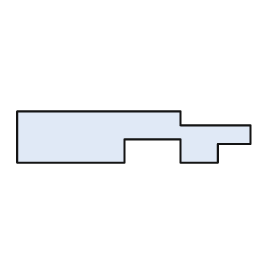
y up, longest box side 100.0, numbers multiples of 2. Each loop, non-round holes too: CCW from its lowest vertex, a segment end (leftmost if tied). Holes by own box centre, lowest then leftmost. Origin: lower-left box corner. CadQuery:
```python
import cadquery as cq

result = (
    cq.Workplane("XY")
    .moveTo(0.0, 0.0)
    .lineTo(46.0, 0.0)
    .lineTo(46.0, 10.0)
    .lineTo(70.0, 10.0)
    .lineTo(70.0, 0.0)
    .lineTo(86.0, 0.0)
    .lineTo(86.0, 8.0)
    .lineTo(100.0, 8.0)
    .lineTo(100.0, 16.0)
    .lineTo(70.0, 16.0)
    .lineTo(70.0, 22.0)
    .lineTo(0.0, 22.0)
    .close()
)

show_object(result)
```